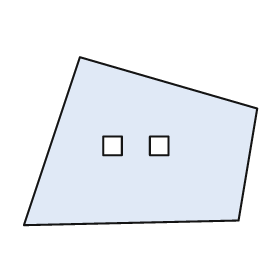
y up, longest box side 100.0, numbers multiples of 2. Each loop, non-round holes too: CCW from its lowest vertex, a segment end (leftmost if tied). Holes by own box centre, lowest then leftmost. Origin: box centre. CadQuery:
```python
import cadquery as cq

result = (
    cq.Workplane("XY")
    .moveTo(-50.0, -36.0)
    .lineTo(42.0, -34.0)
    .lineTo(50.0, 14.0)
    .lineTo(-26.0, 36.0)
    .close()
    .moveTo(-16.0, -6.0)
    .lineTo(-8.0, -6.0)
    .lineTo(-8.0, 2.0)
    .lineTo(-16.0, 2.0)
    .close()
    .moveTo(4.0, -6.0)
    .lineTo(12.0, -6.0)
    .lineTo(12.0, 2.0)
    .lineTo(4.0, 2.0)
    .close()
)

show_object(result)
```